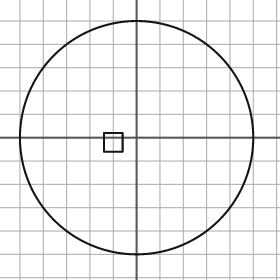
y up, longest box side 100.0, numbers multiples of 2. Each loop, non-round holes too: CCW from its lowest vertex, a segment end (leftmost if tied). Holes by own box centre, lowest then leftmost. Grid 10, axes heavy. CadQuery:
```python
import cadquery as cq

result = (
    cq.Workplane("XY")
    .moveTo(0.0, 0.0)
    .circle(50.0)
    .moveTo(-14.0, -6.0)
    .lineTo(-6.0, -6.0)
    .lineTo(-6.0, 2.0)
    .lineTo(-14.0, 2.0)
    .close()
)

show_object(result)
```